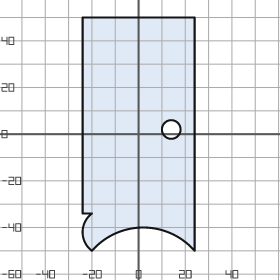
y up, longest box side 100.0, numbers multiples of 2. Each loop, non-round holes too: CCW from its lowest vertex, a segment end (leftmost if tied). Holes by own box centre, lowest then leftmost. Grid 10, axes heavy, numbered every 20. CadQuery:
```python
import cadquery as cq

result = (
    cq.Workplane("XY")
    .moveTo(-20.0, -50.0)
    .threePointArc((2.0, -40.0), (24.0, -50.0))
    .lineTo(24.0, 50.0)
    .lineTo(-24.0, 50.0)
    .lineTo(-24.0, -34.0)
    .lineTo(-20.0, -34.0)
    .threePointArc((-24.0, -42.0), (-20.0, -50.0))
    .close()
    .moveTo(14.0, 2.0)
    .circle(4.0)
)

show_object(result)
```